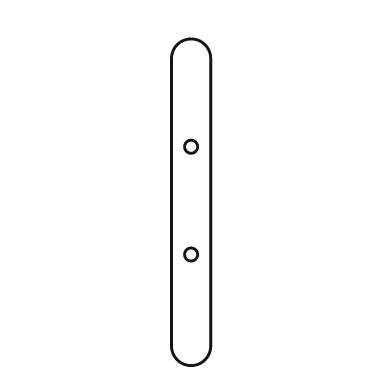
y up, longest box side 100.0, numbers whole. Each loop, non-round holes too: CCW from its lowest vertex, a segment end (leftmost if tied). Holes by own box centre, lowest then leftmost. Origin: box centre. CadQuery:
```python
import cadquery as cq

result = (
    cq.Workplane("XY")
    .moveTo(-6.0, -44.0)
    .threePointArc((0.0, -50.0), (6.0, -44.0))
    .lineTo(6.0, 44.0)
    .threePointArc((0.0, 50.0), (-6.0, 44.0))
    .close()
    .moveTo(0.0, -16.0)
    .circle(2.0)
    .moveTo(0.0, 17.0)
    .circle(2.0)
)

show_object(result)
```